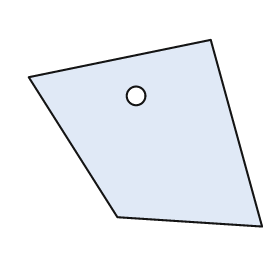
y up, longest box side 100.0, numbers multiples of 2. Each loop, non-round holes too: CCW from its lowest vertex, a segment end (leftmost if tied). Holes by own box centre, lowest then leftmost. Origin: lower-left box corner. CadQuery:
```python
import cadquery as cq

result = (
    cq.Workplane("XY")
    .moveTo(100.0, 0.0)
    .lineTo(78.0, 80.0)
    .lineTo(0.0, 64.0)
    .lineTo(38.0, 4.0)
    .close()
    .moveTo(46.0, 56.0)
    .circle(4.0)
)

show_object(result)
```